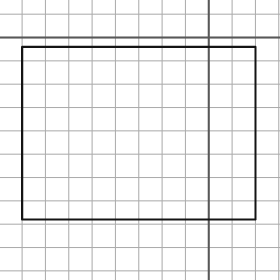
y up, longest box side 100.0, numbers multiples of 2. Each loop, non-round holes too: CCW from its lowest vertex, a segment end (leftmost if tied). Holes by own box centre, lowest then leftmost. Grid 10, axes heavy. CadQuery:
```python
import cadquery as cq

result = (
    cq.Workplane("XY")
    .moveTo(-80.0, -78.0)
    .lineTo(20.0, -78.0)
    .lineTo(20.0, -4.0)
    .lineTo(-80.0, -4.0)
    .close()
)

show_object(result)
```